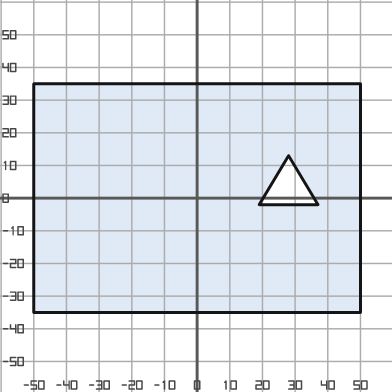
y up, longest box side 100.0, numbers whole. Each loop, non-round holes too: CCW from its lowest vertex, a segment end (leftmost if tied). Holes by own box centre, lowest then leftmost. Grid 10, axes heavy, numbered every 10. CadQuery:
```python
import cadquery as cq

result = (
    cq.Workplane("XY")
    .moveTo(-50.0, -35.0)
    .lineTo(50.0, -35.0)
    .lineTo(50.0, 35.0)
    .lineTo(-50.0, 35.0)
    .close()
    .moveTo(19.0, -2.0)
    .lineTo(37.0, -2.0)
    .lineTo(28.0, 13.0)
    .close()
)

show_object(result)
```